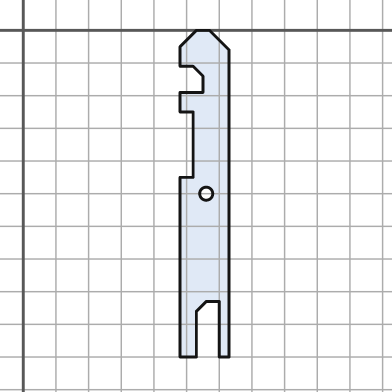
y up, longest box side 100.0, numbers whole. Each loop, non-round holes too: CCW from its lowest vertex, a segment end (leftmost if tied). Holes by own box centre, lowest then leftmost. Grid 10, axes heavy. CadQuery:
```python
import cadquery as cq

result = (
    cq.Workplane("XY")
    .moveTo(48.0, -100.0)
    .lineTo(53.0, -100.0)
    .lineTo(53.0, -86.0)
    .lineTo(56.0, -83.0)
    .lineTo(60.0, -83.0)
    .lineTo(60.0, -100.0)
    .lineTo(63.0, -100.0)
    .lineTo(63.0, -6.0)
    .lineTo(57.0, 0.0)
    .lineTo(53.0, 0.0)
    .lineTo(48.0, -5.0)
    .lineTo(48.0, -11.0)
    .lineTo(52.0, -11.0)
    .lineTo(55.0, -14.0)
    .lineTo(55.0, -19.0)
    .lineTo(48.0, -19.0)
    .lineTo(48.0, -25.0)
    .lineTo(52.0, -25.0)
    .lineTo(52.0, -45.0)
    .lineTo(48.0, -45.0)
    .close()
    .moveTo(56.0, -50.0)
    .circle(2.0)
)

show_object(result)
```